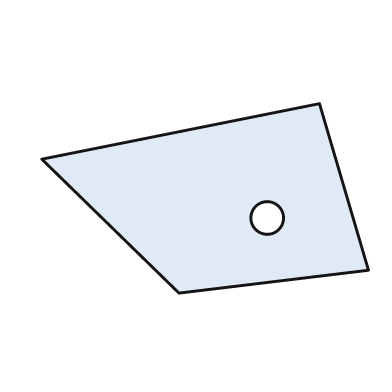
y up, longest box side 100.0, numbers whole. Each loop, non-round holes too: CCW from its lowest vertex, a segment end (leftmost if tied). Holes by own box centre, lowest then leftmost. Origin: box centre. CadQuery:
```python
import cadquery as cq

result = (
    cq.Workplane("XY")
    .moveTo(-8.0, -29.0)
    .lineTo(50.0, -22.0)
    .lineTo(35.0, 29.0)
    .lineTo(-50.0, 12.0)
    .close()
    .moveTo(19.0, -6.0)
    .circle(5.0)
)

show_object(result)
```